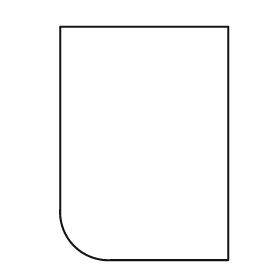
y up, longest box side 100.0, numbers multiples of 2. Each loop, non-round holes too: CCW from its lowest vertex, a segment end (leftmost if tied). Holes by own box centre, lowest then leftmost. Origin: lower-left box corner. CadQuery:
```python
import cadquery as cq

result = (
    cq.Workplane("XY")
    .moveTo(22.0, 0.0)
    .lineTo(72.0, 0.0)
    .lineTo(72.0, 100.0)
    .lineTo(0.0, 100.0)
    .lineTo(0.0, 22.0)
    .threePointArc((6.0, 6.0), (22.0, 0.0))
    .close()
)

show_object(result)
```